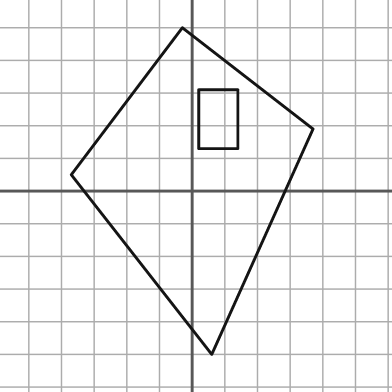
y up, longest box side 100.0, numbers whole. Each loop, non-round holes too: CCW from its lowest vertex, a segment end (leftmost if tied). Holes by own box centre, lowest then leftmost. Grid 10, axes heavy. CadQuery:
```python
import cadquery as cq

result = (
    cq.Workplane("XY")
    .moveTo(6.0, -50.0)
    .lineTo(37.0, 19.0)
    .lineTo(-3.0, 50.0)
    .lineTo(-37.0, 5.0)
    .close()
    .moveTo(2.0, 13.0)
    .lineTo(14.0, 13.0)
    .lineTo(14.0, 31.0)
    .lineTo(2.0, 31.0)
    .close()
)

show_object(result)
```